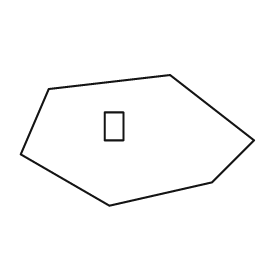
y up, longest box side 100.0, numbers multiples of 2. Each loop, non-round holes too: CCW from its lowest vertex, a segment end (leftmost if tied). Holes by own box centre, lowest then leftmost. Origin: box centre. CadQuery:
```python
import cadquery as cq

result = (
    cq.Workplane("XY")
    .moveTo(-12.0, -28.0)
    .lineTo(32.0, -18.0)
    .lineTo(50.0, 0.0)
    .lineTo(14.0, 28.0)
    .lineTo(-38.0, 22.0)
    .lineTo(-50.0, -6.0)
    .close()
    .moveTo(-14.0, 0.0)
    .lineTo(-6.0, 0.0)
    .lineTo(-6.0, 12.0)
    .lineTo(-14.0, 12.0)
    .close()
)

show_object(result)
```